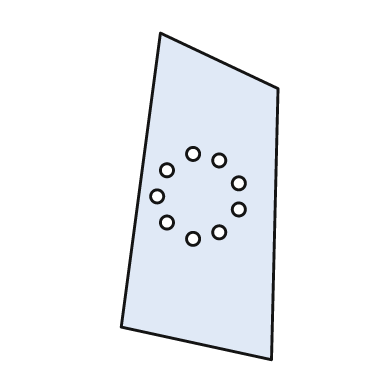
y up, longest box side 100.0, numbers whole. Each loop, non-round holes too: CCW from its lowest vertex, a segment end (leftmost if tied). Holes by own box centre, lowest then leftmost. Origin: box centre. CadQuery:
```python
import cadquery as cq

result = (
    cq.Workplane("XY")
    .moveTo(22.0, -50.0)
    .lineTo(24.0, 33.0)
    .lineTo(-12.0, 50.0)
    .lineTo(-24.0, -40.0)
    .close()
    .moveTo(-2.0, -13.0)
    .circle(2.0)
    .moveTo(6.0, -11.0)
    .circle(2.0)
    .moveTo(-10.0, -8.0)
    .circle(2.0)
    .moveTo(12.0, -4.0)
    .circle(2.0)
    .moveTo(-13.0, 0.0)
    .circle(2.0)
    .moveTo(12.0, 4.0)
    .circle(2.0)
    .moveTo(-10.0, 8.0)
    .circle(2.0)
    .moveTo(6.0, 11.0)
    .circle(2.0)
    .moveTo(-2.0, 13.0)
    .circle(2.0)
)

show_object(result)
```